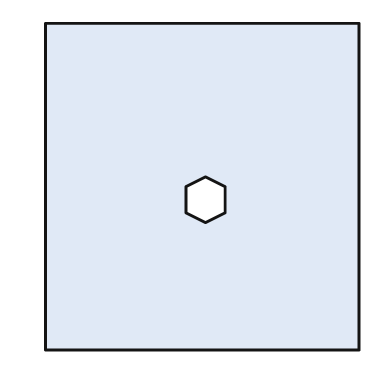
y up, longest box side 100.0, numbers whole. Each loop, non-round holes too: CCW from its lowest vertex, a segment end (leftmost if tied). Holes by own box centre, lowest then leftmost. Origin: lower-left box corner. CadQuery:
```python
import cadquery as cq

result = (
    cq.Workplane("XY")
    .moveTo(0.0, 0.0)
    .lineTo(96.0, 0.0)
    .lineTo(96.0, 100.0)
    .lineTo(0.0, 100.0)
    .close()
    .moveTo(49.0, 39.0)
    .lineTo(55.0, 42.0)
    .lineTo(55.0, 50.0)
    .lineTo(49.0, 53.0)
    .lineTo(43.0, 50.0)
    .lineTo(43.0, 42.0)
    .close()
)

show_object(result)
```